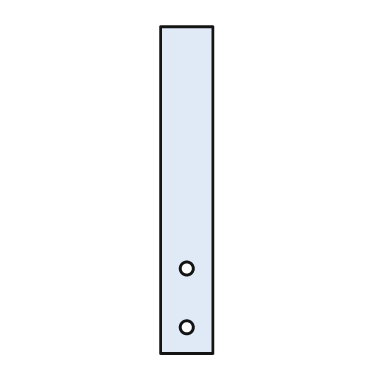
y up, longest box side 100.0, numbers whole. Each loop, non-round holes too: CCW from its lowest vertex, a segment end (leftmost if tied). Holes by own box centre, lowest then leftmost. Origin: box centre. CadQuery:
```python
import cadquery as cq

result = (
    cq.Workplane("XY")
    .moveTo(-8.0, -50.0)
    .lineTo(8.0, -50.0)
    .lineTo(8.0, 50.0)
    .lineTo(-8.0, 50.0)
    .close()
    .moveTo(0.0, -42.0)
    .circle(2.0)
    .moveTo(0.0, -24.0)
    .circle(2.0)
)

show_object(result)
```